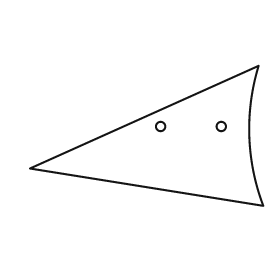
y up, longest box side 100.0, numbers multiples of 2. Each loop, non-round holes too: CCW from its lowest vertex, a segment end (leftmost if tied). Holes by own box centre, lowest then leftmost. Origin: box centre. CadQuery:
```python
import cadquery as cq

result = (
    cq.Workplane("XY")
    .moveTo(50.0, -30.0)
    .threePointArc((44.0, 0.0), (48.0, 30.0))
    .lineTo(-50.0, -14.0)
    .close()
    .moveTo(6.0, 4.0)
    .circle(2.0)
    .moveTo(32.0, 4.0)
    .circle(2.0)
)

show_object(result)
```